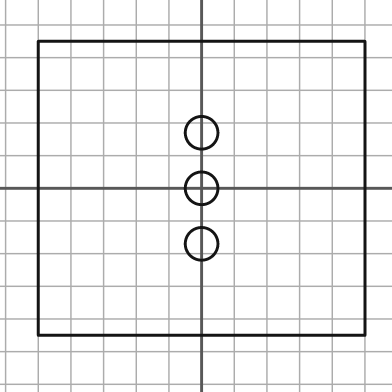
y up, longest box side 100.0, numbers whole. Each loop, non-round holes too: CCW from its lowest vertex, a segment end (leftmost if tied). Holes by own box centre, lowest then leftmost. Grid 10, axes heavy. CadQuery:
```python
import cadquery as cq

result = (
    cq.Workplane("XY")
    .moveTo(-50.0, -45.0)
    .lineTo(50.0, -45.0)
    .lineTo(50.0, 45.0)
    .lineTo(-50.0, 45.0)
    .close()
    .moveTo(0.0, -17.0)
    .circle(5.0)
    .moveTo(0.0, 0.0)
    .circle(5.0)
    .moveTo(0.0, 17.0)
    .circle(5.0)
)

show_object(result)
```